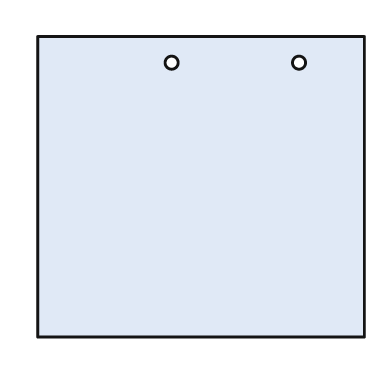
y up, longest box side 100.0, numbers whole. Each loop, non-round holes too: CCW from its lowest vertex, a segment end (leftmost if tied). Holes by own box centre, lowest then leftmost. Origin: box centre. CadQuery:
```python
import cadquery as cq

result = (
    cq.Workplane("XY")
    .moveTo(-50.0, -46.0)
    .lineTo(50.0, -46.0)
    .lineTo(50.0, 46.0)
    .lineTo(-50.0, 46.0)
    .close()
    .moveTo(-9.0, 38.0)
    .circle(2.0)
    .moveTo(30.0, 38.0)
    .circle(2.0)
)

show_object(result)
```